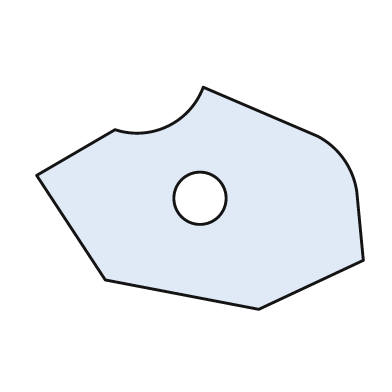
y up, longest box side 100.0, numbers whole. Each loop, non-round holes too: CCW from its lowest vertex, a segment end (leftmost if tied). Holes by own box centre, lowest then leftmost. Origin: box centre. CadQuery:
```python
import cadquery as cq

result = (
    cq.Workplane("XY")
    .moveTo(18.0, -34.0)
    .lineTo(50.0, -19.0)
    .lineTo(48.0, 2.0)
    .threePointArc((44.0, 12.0), (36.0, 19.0))
    .lineTo(1.0, 34.0)
    .threePointArc((-10.0, 22.0), (-26.0, 21.0))
    .lineTo(-50.0, 7.0)
    .lineTo(-29.0, -25.0)
    .close()
    .moveTo(0.0, 0.0)
    .circle(8.0)
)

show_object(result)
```